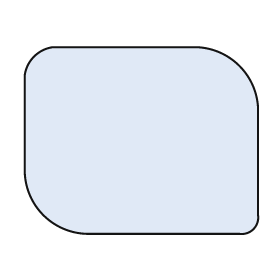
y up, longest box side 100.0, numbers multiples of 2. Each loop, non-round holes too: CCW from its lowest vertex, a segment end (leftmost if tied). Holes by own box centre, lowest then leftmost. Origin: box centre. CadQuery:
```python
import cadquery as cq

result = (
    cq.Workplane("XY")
    .moveTo(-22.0, -40.0)
    .lineTo(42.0, -40.0)
    .threePointArc((48.0, -38.0), (50.0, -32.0))
    .lineTo(50.0, 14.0)
    .threePointArc((42.0, 32.0), (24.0, 40.0))
    .lineTo(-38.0, 40.0)
    .threePointArc((-46.0, 36.0), (-50.0, 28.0))
    .lineTo(-50.0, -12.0)
    .threePointArc((-42.0, -32.0), (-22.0, -40.0))
    .close()
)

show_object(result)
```